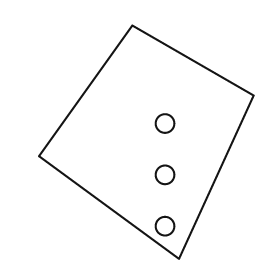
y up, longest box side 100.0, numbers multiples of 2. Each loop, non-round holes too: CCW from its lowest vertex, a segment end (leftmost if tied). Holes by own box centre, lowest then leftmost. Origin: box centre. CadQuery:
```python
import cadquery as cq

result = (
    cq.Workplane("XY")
    .moveTo(14.0, -50.0)
    .lineTo(46.0, 20.0)
    .lineTo(-6.0, 50.0)
    .lineTo(-46.0, -6.0)
    .close()
    .moveTo(8.0, -36.0)
    .circle(4.0)
    .moveTo(8.0, -14.0)
    .circle(4.0)
    .moveTo(8.0, 8.0)
    .circle(4.0)
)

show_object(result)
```